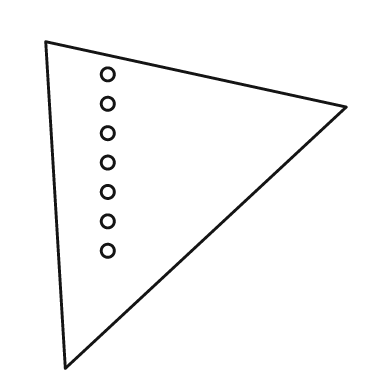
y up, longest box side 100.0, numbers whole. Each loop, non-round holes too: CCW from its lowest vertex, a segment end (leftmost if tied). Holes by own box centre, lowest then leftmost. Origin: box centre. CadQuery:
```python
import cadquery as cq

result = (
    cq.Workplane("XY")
    .moveTo(-40.0, -50.0)
    .lineTo(46.0, 30.0)
    .lineTo(-46.0, 50.0)
    .close()
    .moveTo(-27.0, -14.0)
    .circle(2.0)
    .moveTo(-27.0, -5.0)
    .circle(2.0)
    .moveTo(-27.0, 4.0)
    .circle(2.0)
    .moveTo(-27.0, 13.0)
    .circle(2.0)
    .moveTo(-27.0, 22.0)
    .circle(2.0)
    .moveTo(-27.0, 31.0)
    .circle(2.0)
    .moveTo(-27.0, 40.0)
    .circle(2.0)
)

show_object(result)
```